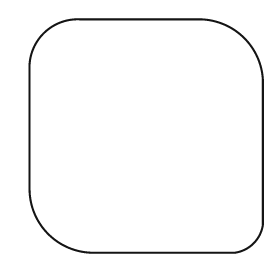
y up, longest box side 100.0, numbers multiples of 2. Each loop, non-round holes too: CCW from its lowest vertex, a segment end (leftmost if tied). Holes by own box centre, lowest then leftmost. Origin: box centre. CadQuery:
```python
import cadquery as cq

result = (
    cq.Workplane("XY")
    .moveTo(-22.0, -50.0)
    .lineTo(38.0, -50.0)
    .threePointArc((46.0, -46.0), (50.0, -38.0))
    .lineTo(50.0, 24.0)
    .threePointArc((42.0, 42.0), (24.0, 50.0))
    .lineTo(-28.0, 50.0)
    .threePointArc((-44.0, 44.0), (-50.0, 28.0))
    .lineTo(-50.0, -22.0)
    .threePointArc((-42.0, -42.0), (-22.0, -50.0))
    .close()
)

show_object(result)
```